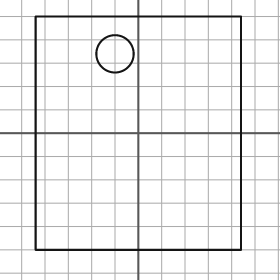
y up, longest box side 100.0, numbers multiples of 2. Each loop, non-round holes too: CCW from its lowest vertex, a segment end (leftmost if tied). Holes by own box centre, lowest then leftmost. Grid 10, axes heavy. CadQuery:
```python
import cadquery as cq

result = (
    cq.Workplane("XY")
    .moveTo(-44.0, -50.0)
    .lineTo(44.0, -50.0)
    .lineTo(44.0, 50.0)
    .lineTo(-44.0, 50.0)
    .close()
    .moveTo(-10.0, 34.0)
    .circle(8.0)
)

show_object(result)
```